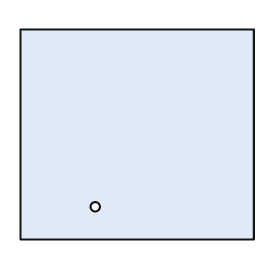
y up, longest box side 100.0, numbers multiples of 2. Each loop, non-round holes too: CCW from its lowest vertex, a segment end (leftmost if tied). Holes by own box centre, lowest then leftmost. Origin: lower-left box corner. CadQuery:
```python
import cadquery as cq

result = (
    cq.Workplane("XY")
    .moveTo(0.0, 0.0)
    .lineTo(100.0, 0.0)
    .lineTo(100.0, 90.0)
    .lineTo(0.0, 90.0)
    .close()
    .moveTo(32.0, 14.0)
    .circle(2.0)
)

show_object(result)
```